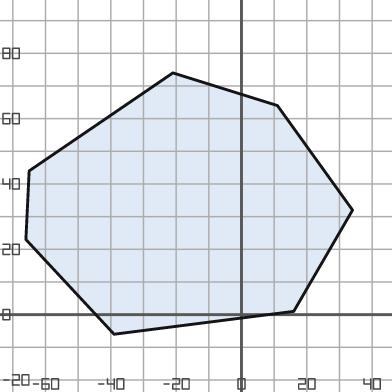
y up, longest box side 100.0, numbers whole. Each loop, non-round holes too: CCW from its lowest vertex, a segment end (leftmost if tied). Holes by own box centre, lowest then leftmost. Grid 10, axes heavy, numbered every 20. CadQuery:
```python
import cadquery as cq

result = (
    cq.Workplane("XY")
    .moveTo(-39.0, -6.0)
    .lineTo(16.0, 1.0)
    .lineTo(34.0, 32.0)
    .lineTo(11.0, 64.0)
    .lineTo(-21.0, 74.0)
    .lineTo(-65.0, 44.0)
    .lineTo(-66.0, 23.0)
    .close()
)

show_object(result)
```